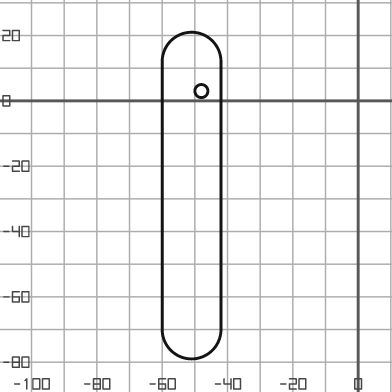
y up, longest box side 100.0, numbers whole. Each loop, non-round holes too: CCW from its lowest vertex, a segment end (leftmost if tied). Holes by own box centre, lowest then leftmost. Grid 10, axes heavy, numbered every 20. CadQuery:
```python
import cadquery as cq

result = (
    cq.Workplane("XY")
    .moveTo(-60.0, -70.0)
    .threePointArc((-51.0, -79.0), (-42.0, -70.0))
    .lineTo(-42.0, 12.0)
    .threePointArc((-51.0, 21.0), (-60.0, 12.0))
    .close()
    .moveTo(-48.0, 3.0)
    .circle(2.0)
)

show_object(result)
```